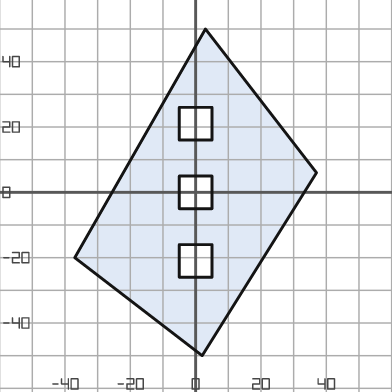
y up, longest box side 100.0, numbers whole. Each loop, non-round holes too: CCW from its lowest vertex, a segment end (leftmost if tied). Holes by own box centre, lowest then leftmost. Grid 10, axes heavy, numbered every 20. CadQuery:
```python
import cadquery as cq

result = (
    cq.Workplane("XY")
    .moveTo(2.0, -50.0)
    .lineTo(37.0, 6.0)
    .lineTo(3.0, 50.0)
    .lineTo(-37.0, -20.0)
    .close()
    .moveTo(-5.0, -26.0)
    .lineTo(5.0, -26.0)
    .lineTo(5.0, -16.0)
    .lineTo(-5.0, -16.0)
    .close()
    .moveTo(-5.0, -5.0)
    .lineTo(5.0, -5.0)
    .lineTo(5.0, 5.0)
    .lineTo(-5.0, 5.0)
    .close()
    .moveTo(-5.0, 16.0)
    .lineTo(5.0, 16.0)
    .lineTo(5.0, 26.0)
    .lineTo(-5.0, 26.0)
    .close()
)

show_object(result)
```